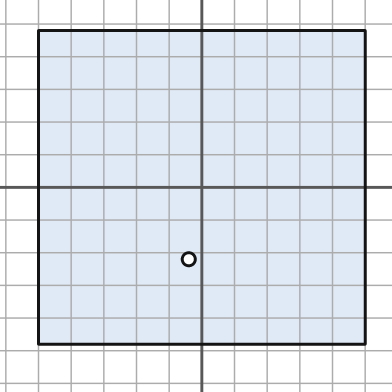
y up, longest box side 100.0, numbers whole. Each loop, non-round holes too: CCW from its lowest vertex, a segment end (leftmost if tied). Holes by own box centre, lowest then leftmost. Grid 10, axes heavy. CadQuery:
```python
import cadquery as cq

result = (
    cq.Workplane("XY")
    .moveTo(-50.0, -48.0)
    .lineTo(50.0, -48.0)
    .lineTo(50.0, 48.0)
    .lineTo(-50.0, 48.0)
    .close()
    .moveTo(-4.0, -22.0)
    .circle(2.0)
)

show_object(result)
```